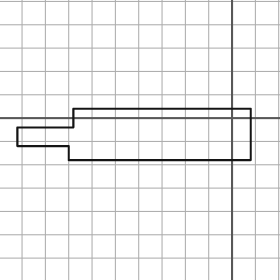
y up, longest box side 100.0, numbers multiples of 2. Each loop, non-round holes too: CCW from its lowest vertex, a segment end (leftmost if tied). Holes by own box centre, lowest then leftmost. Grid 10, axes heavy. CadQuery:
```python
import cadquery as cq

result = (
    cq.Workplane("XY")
    .moveTo(-70.0, -18.0)
    .lineTo(8.0, -18.0)
    .lineTo(8.0, 4.0)
    .lineTo(-68.0, 4.0)
    .lineTo(-68.0, -4.0)
    .lineTo(-92.0, -4.0)
    .lineTo(-92.0, -12.0)
    .lineTo(-70.0, -12.0)
    .close()
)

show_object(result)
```